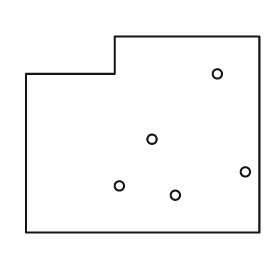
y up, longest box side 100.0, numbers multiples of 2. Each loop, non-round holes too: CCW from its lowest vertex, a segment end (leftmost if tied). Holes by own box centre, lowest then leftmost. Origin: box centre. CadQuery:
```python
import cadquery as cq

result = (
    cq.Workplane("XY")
    .moveTo(-50.0, -42.0)
    .lineTo(50.0, -42.0)
    .lineTo(50.0, 42.0)
    .lineTo(-12.0, 42.0)
    .lineTo(-12.0, 26.0)
    .lineTo(-50.0, 26.0)
    .close()
    .moveTo(14.0, -26.0)
    .circle(2.0)
    .moveTo(-10.0, -22.0)
    .circle(2.0)
    .moveTo(44.0, -16.0)
    .circle(2.0)
    .moveTo(4.0, -2.0)
    .circle(2.0)
    .moveTo(32.0, 26.0)
    .circle(2.0)
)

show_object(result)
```